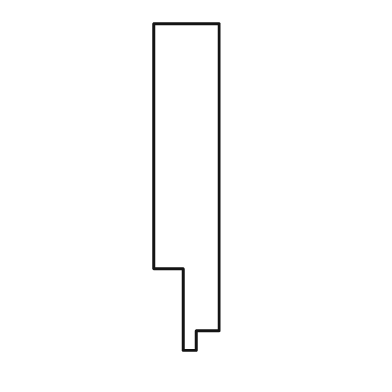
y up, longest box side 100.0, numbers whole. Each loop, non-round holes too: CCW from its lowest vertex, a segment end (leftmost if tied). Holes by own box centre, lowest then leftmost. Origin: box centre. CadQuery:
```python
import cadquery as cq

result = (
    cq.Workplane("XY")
    .moveTo(-1.0, -50.0)
    .lineTo(3.0, -50.0)
    .lineTo(3.0, -44.0)
    .lineTo(10.0, -44.0)
    .lineTo(10.0, 50.0)
    .lineTo(-10.0, 50.0)
    .lineTo(-10.0, -25.0)
    .lineTo(-1.0, -25.0)
    .close()
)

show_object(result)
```